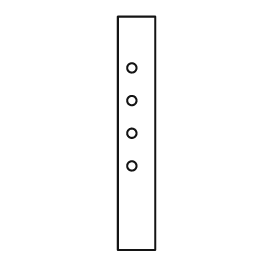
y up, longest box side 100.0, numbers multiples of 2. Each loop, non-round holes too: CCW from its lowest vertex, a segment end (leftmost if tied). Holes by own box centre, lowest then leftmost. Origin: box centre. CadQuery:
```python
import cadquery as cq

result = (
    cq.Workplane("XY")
    .moveTo(-8.0, -50.0)
    .lineTo(8.0, -50.0)
    .lineTo(8.0, 50.0)
    .lineTo(-8.0, 50.0)
    .close()
    .moveTo(-2.0, -14.0)
    .circle(2.0)
    .moveTo(-2.0, 0.0)
    .circle(2.0)
    .moveTo(-2.0, 14.0)
    .circle(2.0)
    .moveTo(-2.0, 28.0)
    .circle(2.0)
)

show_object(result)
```